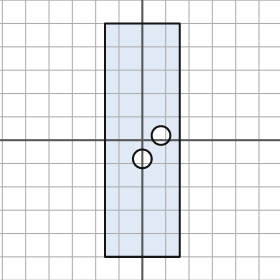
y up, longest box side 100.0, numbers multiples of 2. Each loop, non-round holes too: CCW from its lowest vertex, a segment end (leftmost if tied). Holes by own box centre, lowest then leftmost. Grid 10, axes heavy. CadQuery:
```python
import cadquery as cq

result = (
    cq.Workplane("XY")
    .moveTo(-16.0, -50.0)
    .lineTo(16.0, -50.0)
    .lineTo(16.0, 50.0)
    .lineTo(-16.0, 50.0)
    .close()
    .moveTo(0.0, -8.0)
    .circle(4.0)
    .moveTo(8.0, 2.0)
    .circle(4.0)
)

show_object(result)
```